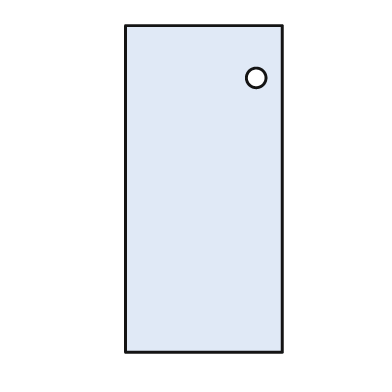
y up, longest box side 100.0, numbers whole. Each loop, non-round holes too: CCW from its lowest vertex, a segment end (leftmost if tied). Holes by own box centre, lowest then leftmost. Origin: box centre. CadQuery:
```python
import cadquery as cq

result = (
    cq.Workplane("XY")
    .moveTo(-24.0, -50.0)
    .lineTo(24.0, -50.0)
    .lineTo(24.0, 50.0)
    .lineTo(-24.0, 50.0)
    .close()
    .moveTo(16.0, 34.0)
    .circle(3.0)
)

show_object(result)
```